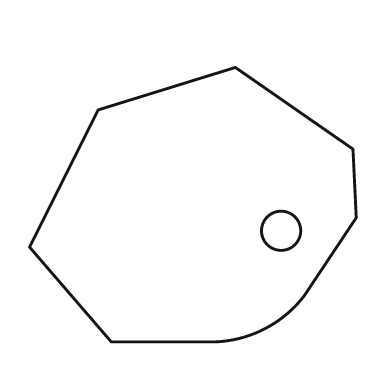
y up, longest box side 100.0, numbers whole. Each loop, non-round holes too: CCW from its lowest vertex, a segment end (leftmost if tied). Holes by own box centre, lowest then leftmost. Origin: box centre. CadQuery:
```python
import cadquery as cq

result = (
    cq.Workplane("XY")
    .moveTo(-25.0, -42.0)
    .lineTo(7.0, -42.0)
    .threePointArc((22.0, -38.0), (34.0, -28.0))
    .lineTo(50.0, -4.0)
    .lineTo(49.0, 17.0)
    .lineTo(13.0, 42.0)
    .lineTo(-29.0, 29.0)
    .lineTo(-50.0, -13.0)
    .close()
    .moveTo(27.0, -8.0)
    .circle(6.0)
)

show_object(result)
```